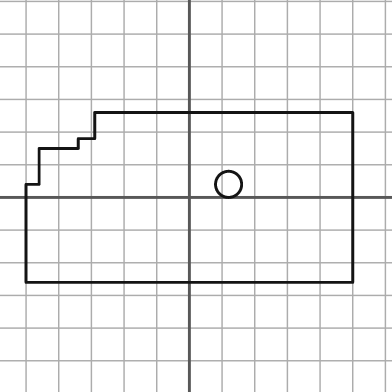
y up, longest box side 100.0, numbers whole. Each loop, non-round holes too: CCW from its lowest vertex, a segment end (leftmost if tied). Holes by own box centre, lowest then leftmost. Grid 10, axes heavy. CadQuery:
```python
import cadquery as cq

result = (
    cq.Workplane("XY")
    .moveTo(-50.0, -26.0)
    .lineTo(50.0, -26.0)
    .lineTo(50.0, 26.0)
    .lineTo(-29.0, 26.0)
    .lineTo(-29.0, 18.0)
    .lineTo(-34.0, 18.0)
    .lineTo(-34.0, 15.0)
    .lineTo(-46.0, 15.0)
    .lineTo(-46.0, 4.0)
    .lineTo(-50.0, 4.0)
    .close()
    .moveTo(12.0, 4.0)
    .circle(4.0)
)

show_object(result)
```